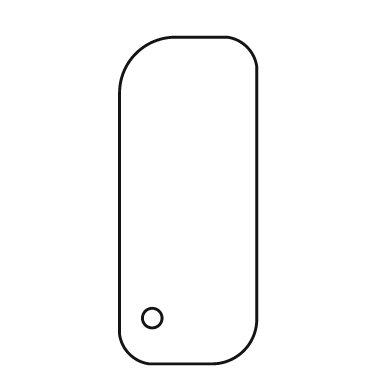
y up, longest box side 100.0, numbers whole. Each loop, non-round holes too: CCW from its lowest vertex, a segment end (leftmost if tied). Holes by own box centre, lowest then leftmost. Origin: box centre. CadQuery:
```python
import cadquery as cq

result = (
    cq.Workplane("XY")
    .moveTo(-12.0, -50.0)
    .lineTo(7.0, -50.0)
    .threePointArc((17.0, -46.0), (21.0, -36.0))
    .lineTo(21.0, 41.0)
    .threePointArc((18.0, 47.0), (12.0, 50.0))
    .lineTo(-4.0, 50.0)
    .threePointArc((-16.0, 45.0), (-21.0, 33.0))
    .lineTo(-21.0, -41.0)
    .threePointArc((-18.0, -47.0), (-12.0, -50.0))
    .close()
    .moveTo(-11.0, -36.0)
    .circle(3.0)
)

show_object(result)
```